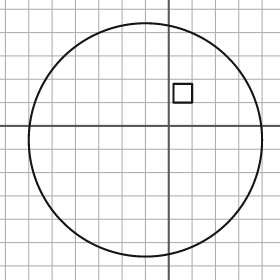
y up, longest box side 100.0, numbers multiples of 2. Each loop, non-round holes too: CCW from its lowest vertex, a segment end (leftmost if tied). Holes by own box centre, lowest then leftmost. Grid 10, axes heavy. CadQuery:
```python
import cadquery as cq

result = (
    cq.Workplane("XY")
    .moveTo(-10.0, -6.0)
    .circle(50.0)
    .moveTo(2.0, 10.0)
    .lineTo(10.0, 10.0)
    .lineTo(10.0, 18.0)
    .lineTo(2.0, 18.0)
    .close()
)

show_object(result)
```